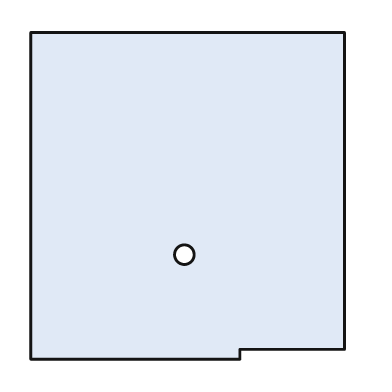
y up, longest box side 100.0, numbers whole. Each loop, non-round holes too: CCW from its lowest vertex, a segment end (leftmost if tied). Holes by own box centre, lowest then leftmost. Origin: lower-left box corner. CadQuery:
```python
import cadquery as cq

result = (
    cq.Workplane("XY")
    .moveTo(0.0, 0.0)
    .lineTo(64.0, 0.0)
    .lineTo(64.0, 3.0)
    .lineTo(96.0, 3.0)
    .lineTo(96.0, 100.0)
    .lineTo(0.0, 100.0)
    .close()
    .moveTo(47.0, 32.0)
    .circle(3.0)
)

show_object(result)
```